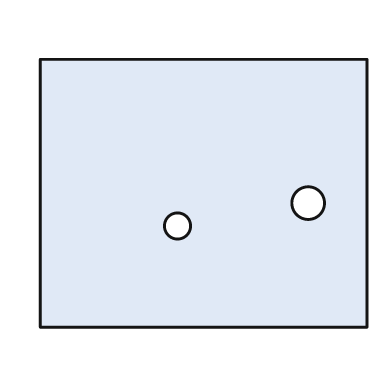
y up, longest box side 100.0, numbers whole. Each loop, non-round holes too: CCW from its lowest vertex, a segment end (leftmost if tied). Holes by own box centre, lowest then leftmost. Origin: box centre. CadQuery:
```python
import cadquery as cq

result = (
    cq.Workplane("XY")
    .moveTo(-50.0, -41.0)
    .lineTo(50.0, -41.0)
    .lineTo(50.0, 41.0)
    .lineTo(-50.0, 41.0)
    .close()
    .moveTo(-8.0, -10.0)
    .circle(4.0)
    .moveTo(32.0, -3.0)
    .circle(5.0)
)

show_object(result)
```